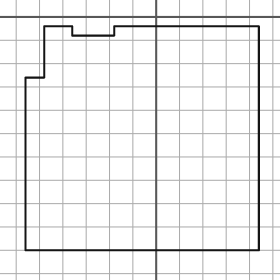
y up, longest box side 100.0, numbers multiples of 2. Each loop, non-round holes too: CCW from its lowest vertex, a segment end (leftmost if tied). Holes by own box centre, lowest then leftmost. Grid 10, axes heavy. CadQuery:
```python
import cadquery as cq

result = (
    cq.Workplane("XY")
    .moveTo(-56.0, -100.0)
    .lineTo(44.0, -100.0)
    .lineTo(44.0, -4.0)
    .lineTo(-18.0, -4.0)
    .lineTo(-18.0, -8.0)
    .lineTo(-36.0, -8.0)
    .lineTo(-36.0, -4.0)
    .lineTo(-48.0, -4.0)
    .lineTo(-48.0, -26.0)
    .lineTo(-56.0, -26.0)
    .close()
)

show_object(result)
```